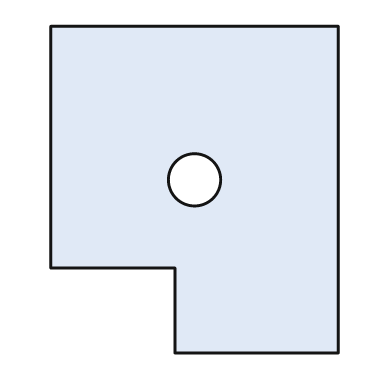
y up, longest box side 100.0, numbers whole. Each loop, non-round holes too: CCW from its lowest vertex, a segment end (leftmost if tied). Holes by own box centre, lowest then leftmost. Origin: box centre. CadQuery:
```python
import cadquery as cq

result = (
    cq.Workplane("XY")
    .moveTo(-6.0, -50.0)
    .lineTo(44.0, -50.0)
    .lineTo(44.0, 50.0)
    .lineTo(-44.0, 50.0)
    .lineTo(-44.0, -24.0)
    .lineTo(-6.0, -24.0)
    .close()
    .moveTo(0.0, 3.0)
    .circle(8.0)
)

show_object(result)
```